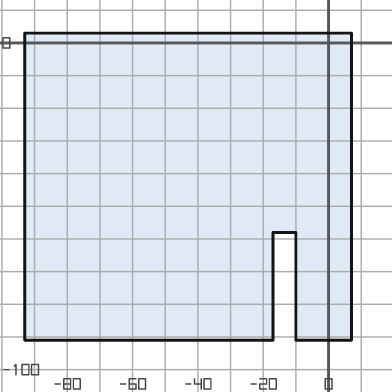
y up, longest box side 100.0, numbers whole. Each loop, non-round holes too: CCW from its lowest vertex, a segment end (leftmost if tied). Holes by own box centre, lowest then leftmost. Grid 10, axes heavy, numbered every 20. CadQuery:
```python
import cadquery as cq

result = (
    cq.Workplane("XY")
    .moveTo(-93.0, -91.0)
    .lineTo(-17.0, -91.0)
    .lineTo(-17.0, -58.0)
    .lineTo(-10.0, -58.0)
    .lineTo(-10.0, -91.0)
    .lineTo(7.0, -91.0)
    .lineTo(7.0, 3.0)
    .lineTo(-93.0, 3.0)
    .close()
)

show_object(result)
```